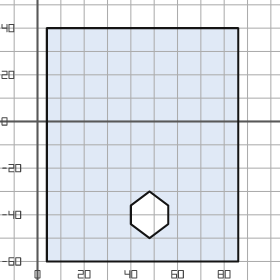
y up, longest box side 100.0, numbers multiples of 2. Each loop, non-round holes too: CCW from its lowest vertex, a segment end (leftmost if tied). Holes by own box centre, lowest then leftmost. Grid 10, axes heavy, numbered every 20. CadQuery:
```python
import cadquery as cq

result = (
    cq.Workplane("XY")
    .moveTo(4.0, -60.0)
    .lineTo(86.0, -60.0)
    .lineTo(86.0, 40.0)
    .lineTo(4.0, 40.0)
    .close()
    .moveTo(48.0, -50.0)
    .lineTo(56.0, -44.0)
    .lineTo(56.0, -36.0)
    .lineTo(48.0, -30.0)
    .lineTo(40.0, -36.0)
    .lineTo(40.0, -44.0)
    .close()
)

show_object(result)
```